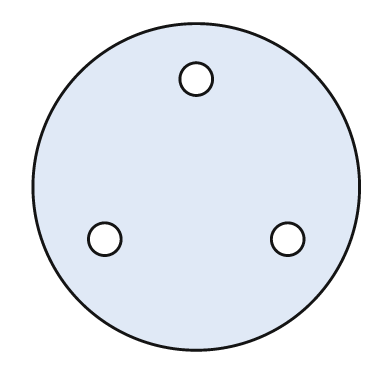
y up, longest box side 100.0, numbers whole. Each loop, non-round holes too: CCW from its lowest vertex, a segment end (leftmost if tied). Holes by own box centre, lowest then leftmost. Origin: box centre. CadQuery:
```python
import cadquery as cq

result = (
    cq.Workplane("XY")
    .moveTo(0.0, 0.0)
    .circle(50.0)
    .moveTo(-28.0, -16.0)
    .circle(5.0)
    .moveTo(28.0, -16.0)
    .circle(5.0)
    .moveTo(0.0, 33.0)
    .circle(5.0)
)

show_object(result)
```